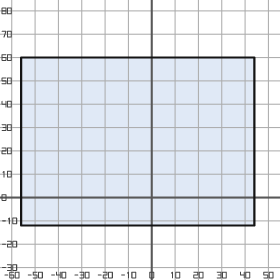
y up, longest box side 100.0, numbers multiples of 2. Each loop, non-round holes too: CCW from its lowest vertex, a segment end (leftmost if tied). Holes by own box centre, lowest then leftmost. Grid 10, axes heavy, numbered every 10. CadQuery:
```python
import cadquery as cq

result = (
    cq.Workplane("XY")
    .moveTo(-56.0, -12.0)
    .lineTo(44.0, -12.0)
    .lineTo(44.0, 60.0)
    .lineTo(-56.0, 60.0)
    .close()
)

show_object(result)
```